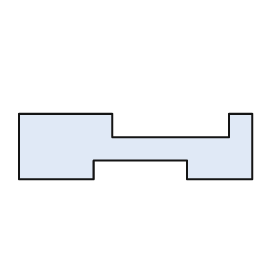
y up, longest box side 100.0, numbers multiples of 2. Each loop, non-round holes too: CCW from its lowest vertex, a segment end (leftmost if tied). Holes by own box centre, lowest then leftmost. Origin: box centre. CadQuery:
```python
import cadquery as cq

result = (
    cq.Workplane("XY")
    .moveTo(-50.0, -14.0)
    .lineTo(-18.0, -14.0)
    .lineTo(-18.0, -6.0)
    .lineTo(22.0, -6.0)
    .lineTo(22.0, -14.0)
    .lineTo(50.0, -14.0)
    .lineTo(50.0, 14.0)
    .lineTo(40.0, 14.0)
    .lineTo(40.0, 4.0)
    .lineTo(-10.0, 4.0)
    .lineTo(-10.0, 14.0)
    .lineTo(-50.0, 14.0)
    .close()
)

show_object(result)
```